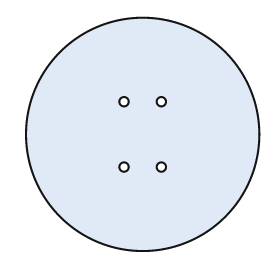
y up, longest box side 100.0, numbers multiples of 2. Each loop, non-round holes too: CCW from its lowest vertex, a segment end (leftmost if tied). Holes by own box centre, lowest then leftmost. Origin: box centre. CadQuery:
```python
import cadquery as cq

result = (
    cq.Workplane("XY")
    .moveTo(0.0, 0.0)
    .circle(50.0)
    .moveTo(-8.0, -14.0)
    .circle(2.0)
    .moveTo(8.0, -14.0)
    .circle(2.0)
    .moveTo(-8.0, 14.0)
    .circle(2.0)
    .moveTo(8.0, 14.0)
    .circle(2.0)
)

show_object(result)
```